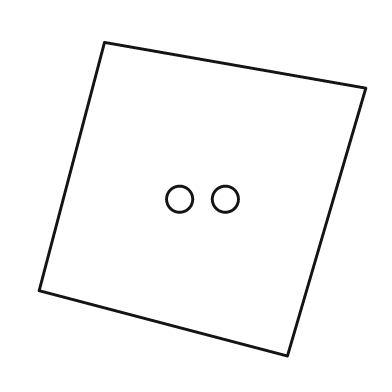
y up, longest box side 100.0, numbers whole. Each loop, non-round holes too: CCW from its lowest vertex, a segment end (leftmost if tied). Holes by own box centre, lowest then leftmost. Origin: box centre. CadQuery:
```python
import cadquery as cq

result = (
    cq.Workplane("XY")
    .moveTo(26.0, -48.0)
    .lineTo(50.0, 34.0)
    .lineTo(-30.0, 48.0)
    .lineTo(-50.0, -28.0)
    .close()
    .moveTo(-7.0, 0.0)
    .circle(4.0)
    .moveTo(7.0, 0.0)
    .circle(4.0)
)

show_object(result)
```